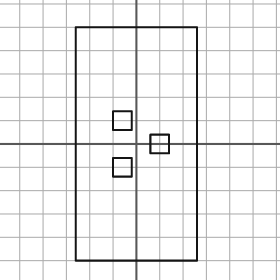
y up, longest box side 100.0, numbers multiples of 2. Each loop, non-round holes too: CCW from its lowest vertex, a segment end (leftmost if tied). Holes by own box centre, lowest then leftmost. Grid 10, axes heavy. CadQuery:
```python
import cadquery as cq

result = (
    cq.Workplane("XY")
    .moveTo(-26.0, -50.0)
    .lineTo(26.0, -50.0)
    .lineTo(26.0, 50.0)
    .lineTo(-26.0, 50.0)
    .close()
    .moveTo(-10.0, -14.0)
    .lineTo(-2.0, -14.0)
    .lineTo(-2.0, -6.0)
    .lineTo(-10.0, -6.0)
    .close()
    .moveTo(6.0, -4.0)
    .lineTo(14.0, -4.0)
    .lineTo(14.0, 4.0)
    .lineTo(6.0, 4.0)
    .close()
    .moveTo(-10.0, 6.0)
    .lineTo(-2.0, 6.0)
    .lineTo(-2.0, 14.0)
    .lineTo(-10.0, 14.0)
    .close()
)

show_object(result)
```